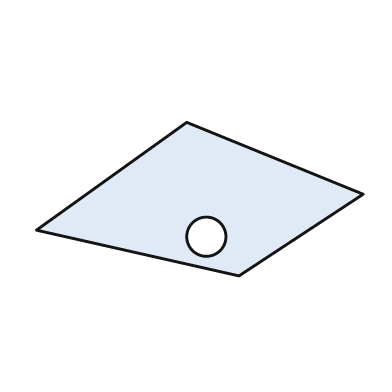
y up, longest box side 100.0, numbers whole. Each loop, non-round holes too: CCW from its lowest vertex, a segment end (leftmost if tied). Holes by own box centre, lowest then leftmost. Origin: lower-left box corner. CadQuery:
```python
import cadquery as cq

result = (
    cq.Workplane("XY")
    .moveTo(62.0, 0.0)
    .lineTo(100.0, 25.0)
    .lineTo(46.0, 47.0)
    .lineTo(0.0, 14.0)
    .close()
    .moveTo(52.0, 12.0)
    .circle(6.0)
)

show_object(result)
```